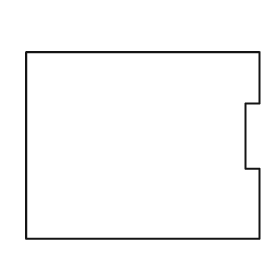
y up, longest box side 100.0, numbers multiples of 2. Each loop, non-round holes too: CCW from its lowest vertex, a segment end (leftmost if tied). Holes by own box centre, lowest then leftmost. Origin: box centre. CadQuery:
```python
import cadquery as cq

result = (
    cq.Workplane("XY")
    .moveTo(-50.0, -40.0)
    .lineTo(50.0, -40.0)
    .lineTo(50.0, -10.0)
    .lineTo(44.0, -10.0)
    .lineTo(44.0, 18.0)
    .lineTo(50.0, 18.0)
    .lineTo(50.0, 40.0)
    .lineTo(-50.0, 40.0)
    .close()
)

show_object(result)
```